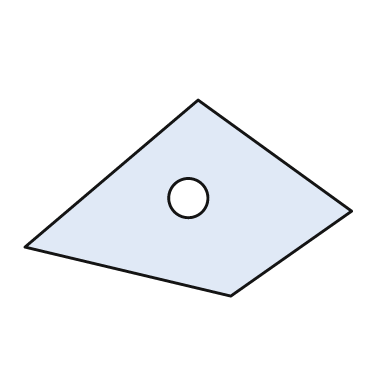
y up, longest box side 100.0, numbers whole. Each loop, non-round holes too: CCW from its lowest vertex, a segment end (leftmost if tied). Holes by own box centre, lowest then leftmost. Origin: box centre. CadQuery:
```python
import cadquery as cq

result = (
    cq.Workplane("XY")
    .moveTo(13.0, -30.0)
    .lineTo(50.0, -4.0)
    .lineTo(3.0, 30.0)
    .lineTo(-50.0, -15.0)
    .close()
    .moveTo(0.0, 0.0)
    .circle(6.0)
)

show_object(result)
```